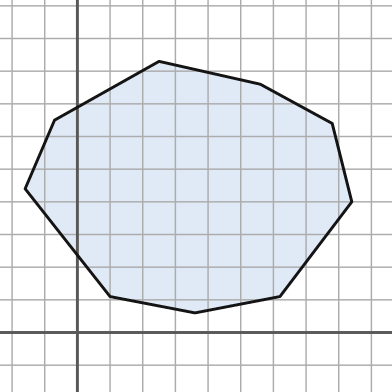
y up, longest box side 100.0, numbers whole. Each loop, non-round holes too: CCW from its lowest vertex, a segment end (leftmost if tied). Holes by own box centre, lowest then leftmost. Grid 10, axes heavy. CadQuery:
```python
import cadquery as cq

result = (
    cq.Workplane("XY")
    .moveTo(36.0, 6.0)
    .lineTo(62.0, 11.0)
    .lineTo(84.0, 40.0)
    .lineTo(78.0, 64.0)
    .lineTo(56.0, 76.0)
    .lineTo(25.0, 83.0)
    .lineTo(-7.0, 65.0)
    .lineTo(-16.0, 44.0)
    .lineTo(10.0, 11.0)
    .close()
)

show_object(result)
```